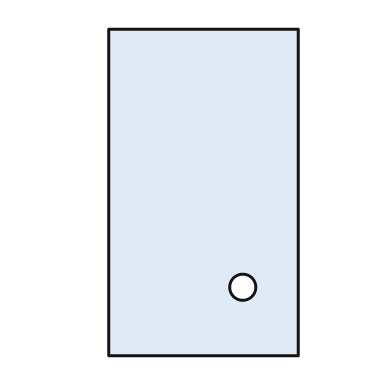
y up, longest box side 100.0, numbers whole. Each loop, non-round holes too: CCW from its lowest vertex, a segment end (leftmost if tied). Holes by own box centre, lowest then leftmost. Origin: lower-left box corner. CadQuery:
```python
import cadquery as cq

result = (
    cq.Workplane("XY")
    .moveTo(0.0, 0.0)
    .lineTo(58.0, 0.0)
    .lineTo(58.0, 100.0)
    .lineTo(0.0, 100.0)
    .close()
    .moveTo(41.0, 21.0)
    .circle(4.0)
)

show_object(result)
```